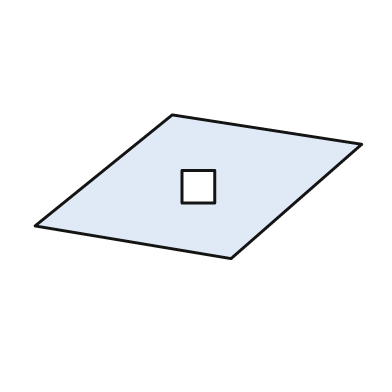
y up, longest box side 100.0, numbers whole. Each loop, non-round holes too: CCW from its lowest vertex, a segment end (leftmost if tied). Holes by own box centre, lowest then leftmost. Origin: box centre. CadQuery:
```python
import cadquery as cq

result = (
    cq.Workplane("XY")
    .moveTo(10.0, -22.0)
    .lineTo(50.0, 13.0)
    .lineTo(-8.0, 22.0)
    .lineTo(-50.0, -12.0)
    .close()
    .moveTo(-5.0, -5.0)
    .lineTo(5.0, -5.0)
    .lineTo(5.0, 5.0)
    .lineTo(-5.0, 5.0)
    .close()
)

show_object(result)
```